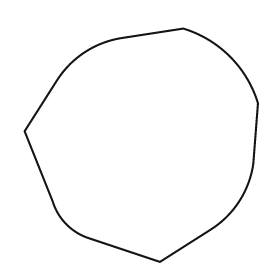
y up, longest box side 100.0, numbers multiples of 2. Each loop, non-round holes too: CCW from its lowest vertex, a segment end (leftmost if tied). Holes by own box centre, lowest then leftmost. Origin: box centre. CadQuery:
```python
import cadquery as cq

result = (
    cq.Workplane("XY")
    .moveTo(8.0, -50.0)
    .lineTo(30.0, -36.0)
    .threePointArc((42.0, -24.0), (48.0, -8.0))
    .lineTo(50.0, 18.0)
    .threePointArc((38.0, 38.0), (18.0, 50.0))
    .lineTo(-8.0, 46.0)
    .threePointArc((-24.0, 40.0), (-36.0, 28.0))
    .lineTo(-50.0, 6.0)
    .lineTo(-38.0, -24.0)
    .threePointArc((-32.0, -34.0), (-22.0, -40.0))
    .close()
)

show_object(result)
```